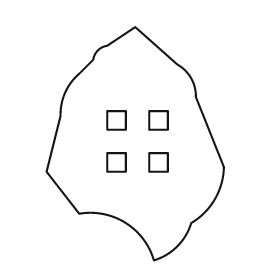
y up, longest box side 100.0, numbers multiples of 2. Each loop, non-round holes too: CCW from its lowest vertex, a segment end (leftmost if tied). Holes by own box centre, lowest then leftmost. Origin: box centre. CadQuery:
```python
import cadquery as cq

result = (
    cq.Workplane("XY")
    .moveTo(8.0, -50.0)
    .threePointArc((18.0, -44.0), (24.0, -34.0))
    .threePointArc((34.0, -24.0), (38.0, -10.0))
    .lineTo(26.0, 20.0)
    .threePointArc((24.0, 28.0), (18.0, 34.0))
    .lineTo(0.0, 50.0)
    .lineTo(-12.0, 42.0)
    .threePointArc((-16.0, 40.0), (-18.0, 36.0))
    .lineTo(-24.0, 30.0)
    .threePointArc((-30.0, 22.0), (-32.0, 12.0))
    .lineTo(-38.0, -12.0)
    .lineTo(-24.0, -30.0)
    .threePointArc((-4.0, -34.0), (8.0, -50.0))
    .close()
    .moveTo(-12.0, -12.0)
    .lineTo(-4.0, -12.0)
    .lineTo(-4.0, -4.0)
    .lineTo(-12.0, -4.0)
    .close()
    .moveTo(6.0, -12.0)
    .lineTo(14.0, -12.0)
    .lineTo(14.0, -4.0)
    .lineTo(6.0, -4.0)
    .close()
    .moveTo(-12.0, 6.0)
    .lineTo(-4.0, 6.0)
    .lineTo(-4.0, 14.0)
    .lineTo(-12.0, 14.0)
    .close()
    .moveTo(6.0, 6.0)
    .lineTo(14.0, 6.0)
    .lineTo(14.0, 14.0)
    .lineTo(6.0, 14.0)
    .close()
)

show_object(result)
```